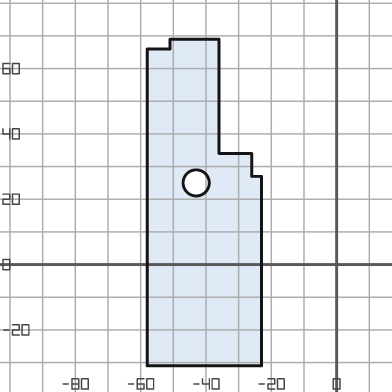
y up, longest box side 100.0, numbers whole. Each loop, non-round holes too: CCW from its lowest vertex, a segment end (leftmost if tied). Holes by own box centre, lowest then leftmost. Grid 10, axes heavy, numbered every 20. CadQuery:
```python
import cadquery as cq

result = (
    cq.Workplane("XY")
    .moveTo(-58.0, -31.0)
    .lineTo(-23.0, -31.0)
    .lineTo(-23.0, 27.0)
    .lineTo(-26.0, 27.0)
    .lineTo(-26.0, 34.0)
    .lineTo(-36.0, 34.0)
    .lineTo(-36.0, 69.0)
    .lineTo(-51.0, 69.0)
    .lineTo(-51.0, 66.0)
    .lineTo(-58.0, 66.0)
    .close()
    .moveTo(-43.0, 25.0)
    .circle(4.0)
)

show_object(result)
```